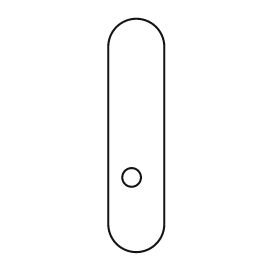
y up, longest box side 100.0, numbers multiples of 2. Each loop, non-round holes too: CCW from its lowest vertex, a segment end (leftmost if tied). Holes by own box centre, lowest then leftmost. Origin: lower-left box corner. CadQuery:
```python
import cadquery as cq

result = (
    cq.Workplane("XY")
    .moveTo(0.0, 12.0)
    .threePointArc((12.0, 0.0), (24.0, 12.0))
    .lineTo(24.0, 88.0)
    .threePointArc((12.0, 100.0), (0.0, 88.0))
    .close()
    .moveTo(10.0, 32.0)
    .circle(4.0)
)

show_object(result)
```